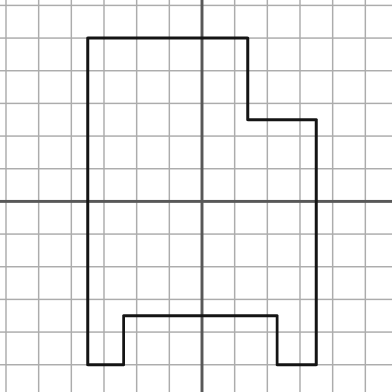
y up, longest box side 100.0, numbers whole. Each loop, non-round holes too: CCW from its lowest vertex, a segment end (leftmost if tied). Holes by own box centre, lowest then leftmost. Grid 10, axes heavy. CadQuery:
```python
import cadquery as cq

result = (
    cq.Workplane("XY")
    .moveTo(-35.0, -50.0)
    .lineTo(-24.0, -50.0)
    .lineTo(-24.0, -35.0)
    .lineTo(23.0, -35.0)
    .lineTo(23.0, -50.0)
    .lineTo(35.0, -50.0)
    .lineTo(35.0, 25.0)
    .lineTo(14.0, 25.0)
    .lineTo(14.0, 50.0)
    .lineTo(-35.0, 50.0)
    .close()
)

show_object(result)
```